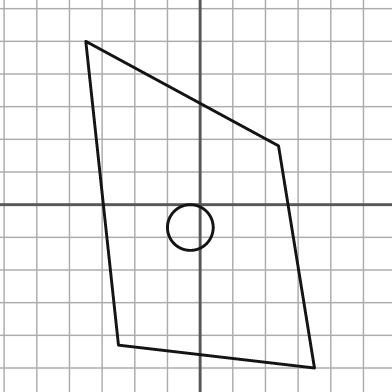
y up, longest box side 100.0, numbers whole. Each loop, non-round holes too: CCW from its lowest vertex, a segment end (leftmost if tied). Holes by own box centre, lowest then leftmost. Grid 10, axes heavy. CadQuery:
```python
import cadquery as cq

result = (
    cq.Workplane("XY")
    .moveTo(35.0, -50.0)
    .lineTo(24.0, 18.0)
    .lineTo(-35.0, 50.0)
    .lineTo(-25.0, -43.0)
    .close()
    .moveTo(-3.0, -7.0)
    .circle(7.0)
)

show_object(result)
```